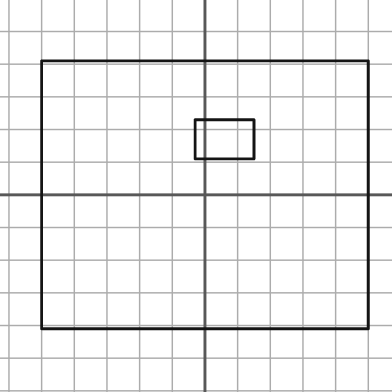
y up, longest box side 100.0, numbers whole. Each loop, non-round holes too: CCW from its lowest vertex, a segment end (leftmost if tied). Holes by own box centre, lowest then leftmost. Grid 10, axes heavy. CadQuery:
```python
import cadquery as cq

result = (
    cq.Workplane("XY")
    .moveTo(-50.0, -41.0)
    .lineTo(50.0, -41.0)
    .lineTo(50.0, 41.0)
    .lineTo(-50.0, 41.0)
    .close()
    .moveTo(-3.0, 11.0)
    .lineTo(15.0, 11.0)
    .lineTo(15.0, 23.0)
    .lineTo(-3.0, 23.0)
    .close()
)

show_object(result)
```